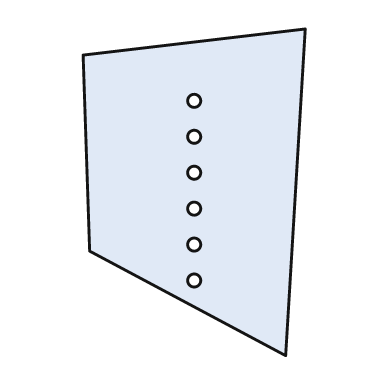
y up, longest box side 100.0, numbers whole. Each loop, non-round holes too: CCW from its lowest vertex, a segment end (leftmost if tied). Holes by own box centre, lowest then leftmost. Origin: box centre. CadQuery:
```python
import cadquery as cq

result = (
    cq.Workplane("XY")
    .moveTo(28.0, -50.0)
    .lineTo(34.0, 50.0)
    .lineTo(-34.0, 42.0)
    .lineTo(-32.0, -18.0)
    .close()
    .moveTo(0.0, -27.0)
    .circle(2.0)
    .moveTo(0.0, -16.0)
    .circle(2.0)
    .moveTo(0.0, -5.0)
    .circle(2.0)
    .moveTo(0.0, 6.0)
    .circle(2.0)
    .moveTo(0.0, 17.0)
    .circle(2.0)
    .moveTo(0.0, 28.0)
    .circle(2.0)
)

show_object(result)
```